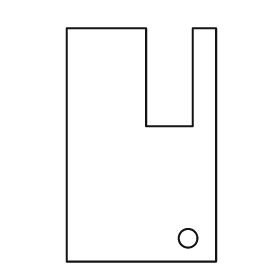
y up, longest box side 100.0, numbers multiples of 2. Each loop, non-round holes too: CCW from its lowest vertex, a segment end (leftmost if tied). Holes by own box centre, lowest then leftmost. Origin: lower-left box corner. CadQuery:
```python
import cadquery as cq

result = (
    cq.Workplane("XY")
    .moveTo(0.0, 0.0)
    .lineTo(64.0, 0.0)
    .lineTo(64.0, 100.0)
    .lineTo(54.0, 100.0)
    .lineTo(54.0, 58.0)
    .lineTo(34.0, 58.0)
    .lineTo(34.0, 100.0)
    .lineTo(0.0, 100.0)
    .close()
    .moveTo(52.0, 10.0)
    .circle(4.0)
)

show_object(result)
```